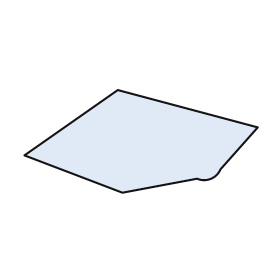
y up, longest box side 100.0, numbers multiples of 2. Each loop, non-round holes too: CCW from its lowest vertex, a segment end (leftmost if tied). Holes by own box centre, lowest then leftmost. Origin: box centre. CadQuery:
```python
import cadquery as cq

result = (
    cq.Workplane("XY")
    .moveTo(-8.0, -22.0)
    .lineTo(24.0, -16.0)
    .threePointArc((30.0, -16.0), (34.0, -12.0))
    .lineTo(50.0, 6.0)
    .lineTo(-10.0, 22.0)
    .lineTo(-50.0, -6.0)
    .close()
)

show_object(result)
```